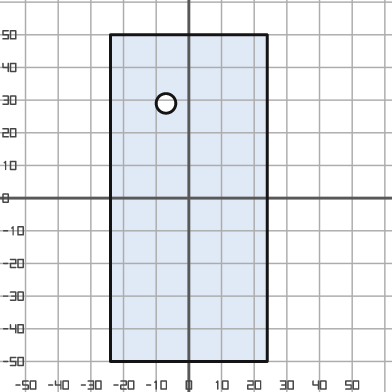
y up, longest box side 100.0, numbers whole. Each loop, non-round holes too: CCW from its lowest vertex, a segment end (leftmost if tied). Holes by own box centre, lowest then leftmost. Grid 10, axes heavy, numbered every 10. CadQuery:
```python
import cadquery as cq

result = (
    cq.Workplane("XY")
    .moveTo(-24.0, -50.0)
    .lineTo(24.0, -50.0)
    .lineTo(24.0, 50.0)
    .lineTo(-24.0, 50.0)
    .close()
    .moveTo(-7.0, 29.0)
    .circle(3.0)
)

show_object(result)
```